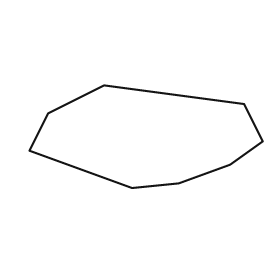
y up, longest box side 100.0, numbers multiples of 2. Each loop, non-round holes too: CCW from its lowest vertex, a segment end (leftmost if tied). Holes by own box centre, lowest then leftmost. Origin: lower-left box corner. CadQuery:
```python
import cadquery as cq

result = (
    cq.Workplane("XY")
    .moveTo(44.0, 0.0)
    .lineTo(64.0, 2.0)
    .lineTo(86.0, 10.0)
    .lineTo(100.0, 20.0)
    .lineTo(92.0, 36.0)
    .lineTo(32.0, 44.0)
    .lineTo(8.0, 32.0)
    .lineTo(0.0, 16.0)
    .close()
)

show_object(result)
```